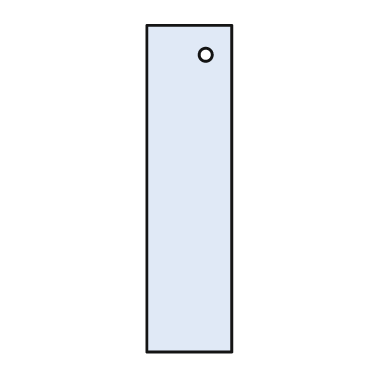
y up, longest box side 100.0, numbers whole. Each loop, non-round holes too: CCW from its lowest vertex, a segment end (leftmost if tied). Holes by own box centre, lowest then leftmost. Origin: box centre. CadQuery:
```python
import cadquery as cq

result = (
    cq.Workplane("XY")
    .moveTo(-13.0, -50.0)
    .lineTo(13.0, -50.0)
    .lineTo(13.0, 50.0)
    .lineTo(-13.0, 50.0)
    .close()
    .moveTo(5.0, 41.0)
    .circle(2.0)
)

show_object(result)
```